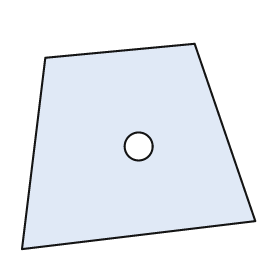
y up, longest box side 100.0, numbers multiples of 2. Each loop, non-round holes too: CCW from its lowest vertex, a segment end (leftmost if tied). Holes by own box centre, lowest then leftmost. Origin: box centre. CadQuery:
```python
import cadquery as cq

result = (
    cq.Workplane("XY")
    .moveTo(-50.0, -44.0)
    .lineTo(50.0, -32.0)
    .lineTo(24.0, 44.0)
    .lineTo(-40.0, 38.0)
    .close()
    .moveTo(0.0, 0.0)
    .circle(6.0)
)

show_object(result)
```